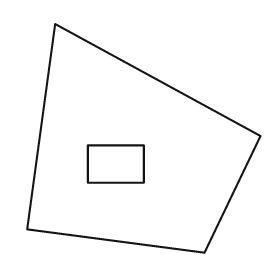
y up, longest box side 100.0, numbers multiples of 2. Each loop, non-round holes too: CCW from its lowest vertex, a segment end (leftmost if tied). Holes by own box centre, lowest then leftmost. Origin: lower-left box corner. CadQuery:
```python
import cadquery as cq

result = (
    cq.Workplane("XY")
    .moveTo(76.0, 0.0)
    .lineTo(100.0, 50.0)
    .lineTo(12.0, 98.0)
    .lineTo(0.0, 10.0)
    .close()
    .moveTo(26.0, 30.0)
    .lineTo(50.0, 30.0)
    .lineTo(50.0, 46.0)
    .lineTo(26.0, 46.0)
    .close()
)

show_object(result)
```